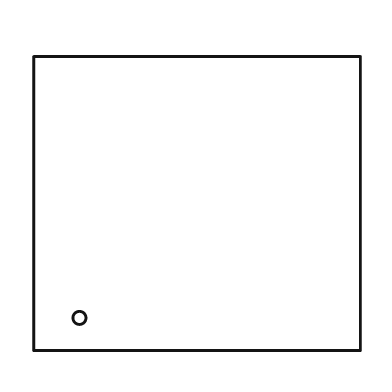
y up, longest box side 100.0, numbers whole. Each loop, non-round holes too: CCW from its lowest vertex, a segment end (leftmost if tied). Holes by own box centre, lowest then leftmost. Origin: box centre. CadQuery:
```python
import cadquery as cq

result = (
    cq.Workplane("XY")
    .moveTo(-50.0, -45.0)
    .lineTo(50.0, -45.0)
    .lineTo(50.0, 45.0)
    .lineTo(-50.0, 45.0)
    .close()
    .moveTo(-36.0, -35.0)
    .circle(2.0)
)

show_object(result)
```